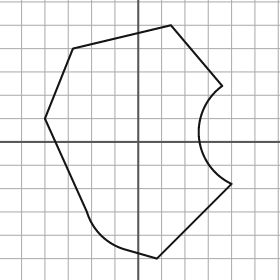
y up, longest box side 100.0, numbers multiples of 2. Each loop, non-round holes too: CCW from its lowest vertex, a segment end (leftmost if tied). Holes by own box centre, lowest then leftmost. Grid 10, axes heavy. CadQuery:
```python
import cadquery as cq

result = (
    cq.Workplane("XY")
    .moveTo(8.0, -50.0)
    .lineTo(40.0, -18.0)
    .threePointArc((26.0, 2.0), (36.0, 24.0))
    .lineTo(14.0, 50.0)
    .lineTo(-28.0, 40.0)
    .lineTo(-40.0, 10.0)
    .lineTo(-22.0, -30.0)
    .threePointArc((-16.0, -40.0), (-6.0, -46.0))
    .close()
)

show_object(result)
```